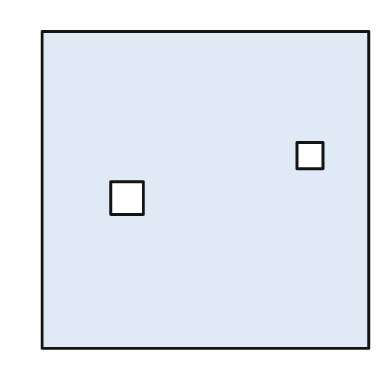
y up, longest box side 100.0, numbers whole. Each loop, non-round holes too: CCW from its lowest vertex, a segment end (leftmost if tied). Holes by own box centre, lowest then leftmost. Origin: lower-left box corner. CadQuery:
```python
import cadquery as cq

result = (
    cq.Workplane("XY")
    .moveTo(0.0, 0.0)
    .lineTo(100.0, 0.0)
    .lineTo(100.0, 97.0)
    .lineTo(0.0, 97.0)
    .close()
    .moveTo(21.0, 41.0)
    .lineTo(31.0, 41.0)
    .lineTo(31.0, 51.0)
    .lineTo(21.0, 51.0)
    .close()
    .moveTo(78.0, 55.0)
    .lineTo(86.0, 55.0)
    .lineTo(86.0, 63.0)
    .lineTo(78.0, 63.0)
    .close()
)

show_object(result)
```